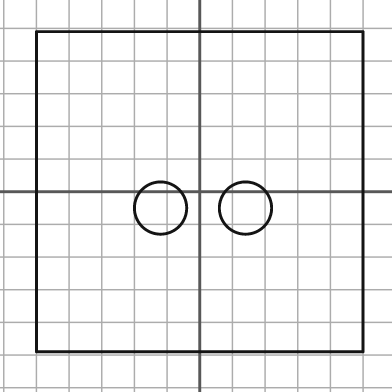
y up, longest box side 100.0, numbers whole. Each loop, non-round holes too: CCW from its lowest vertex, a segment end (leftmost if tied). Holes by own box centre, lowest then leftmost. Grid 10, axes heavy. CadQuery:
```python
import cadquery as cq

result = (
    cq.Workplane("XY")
    .moveTo(-50.0, -49.0)
    .lineTo(50.0, -49.0)
    .lineTo(50.0, 49.0)
    .lineTo(-50.0, 49.0)
    .close()
    .moveTo(-12.0, -5.0)
    .circle(8.0)
    .moveTo(14.0, -5.0)
    .circle(8.0)
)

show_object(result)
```